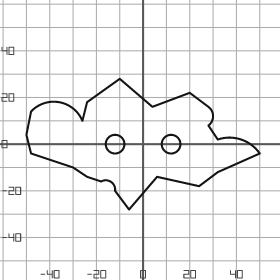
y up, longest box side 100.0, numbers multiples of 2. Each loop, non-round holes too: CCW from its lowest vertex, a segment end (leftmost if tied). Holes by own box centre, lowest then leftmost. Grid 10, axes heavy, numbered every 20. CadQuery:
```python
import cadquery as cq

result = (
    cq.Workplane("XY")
    .moveTo(-6.0, -28.0)
    .lineTo(6.0, -14.0)
    .lineTo(24.0, -18.0)
    .lineTo(32.0, -12.0)
    .lineTo(50.0, -4.0)
    .threePointArc((42.0, 2.0), (32.0, 2.0))
    .lineTo(28.0, 8.0)
    .threePointArc((30.0, 12.0), (28.0, 16.0))
    .lineTo(20.0, 22.0)
    .lineTo(4.0, 16.0)
    .lineTo(-10.0, 28.0)
    .lineTo(-24.0, 18.0)
    .lineTo(-26.0, 10.0)
    .threePointArc((-36.0, 18.0), (-48.0, 14.0))
    .lineTo(-50.0, 4.0)
    .lineTo(-48.0, -4.0)
    .lineTo(-30.0, -10.0)
    .lineTo(-24.0, -14.0)
    .lineTo(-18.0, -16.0)
    .threePointArc((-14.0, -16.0), (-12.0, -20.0))
    .close()
    .moveTo(-12.0, 0.0)
    .circle(4.0)
    .moveTo(12.0, 0.0)
    .circle(4.0)
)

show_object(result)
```